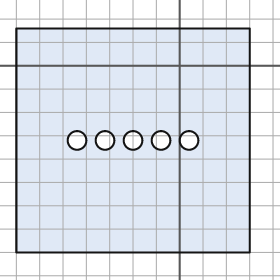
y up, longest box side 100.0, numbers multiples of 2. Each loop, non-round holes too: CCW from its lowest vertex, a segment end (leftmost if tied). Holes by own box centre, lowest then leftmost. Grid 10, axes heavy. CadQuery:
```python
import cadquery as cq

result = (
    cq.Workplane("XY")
    .moveTo(-70.0, -80.0)
    .lineTo(30.0, -80.0)
    .lineTo(30.0, 16.0)
    .lineTo(-70.0, 16.0)
    .close()
    .moveTo(-44.0, -32.0)
    .circle(4.0)
    .moveTo(-32.0, -32.0)
    .circle(4.0)
    .moveTo(-20.0, -32.0)
    .circle(4.0)
    .moveTo(-8.0, -32.0)
    .circle(4.0)
    .moveTo(4.0, -32.0)
    .circle(4.0)
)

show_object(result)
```